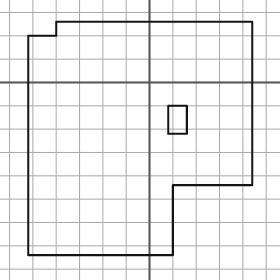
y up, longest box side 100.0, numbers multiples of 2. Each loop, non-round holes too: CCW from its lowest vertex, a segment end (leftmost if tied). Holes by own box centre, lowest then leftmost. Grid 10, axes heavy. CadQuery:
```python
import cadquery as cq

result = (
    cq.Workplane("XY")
    .moveTo(-52.0, -74.0)
    .lineTo(10.0, -74.0)
    .lineTo(10.0, -44.0)
    .lineTo(44.0, -44.0)
    .lineTo(44.0, 26.0)
    .lineTo(-40.0, 26.0)
    .lineTo(-40.0, 20.0)
    .lineTo(-52.0, 20.0)
    .close()
    .moveTo(8.0, -22.0)
    .lineTo(16.0, -22.0)
    .lineTo(16.0, -10.0)
    .lineTo(8.0, -10.0)
    .close()
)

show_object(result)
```